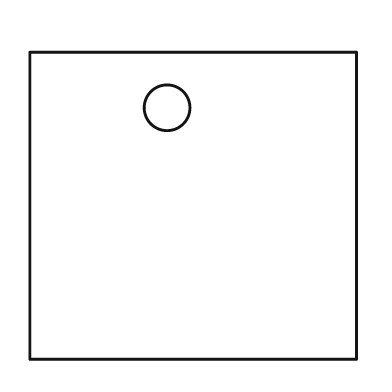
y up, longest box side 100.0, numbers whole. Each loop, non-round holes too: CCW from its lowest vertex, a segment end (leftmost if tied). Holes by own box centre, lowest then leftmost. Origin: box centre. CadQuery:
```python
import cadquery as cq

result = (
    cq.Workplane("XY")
    .moveTo(-50.0, -47.0)
    .lineTo(50.0, -47.0)
    .lineTo(50.0, 47.0)
    .lineTo(-50.0, 47.0)
    .close()
    .moveTo(-8.0, 30.0)
    .circle(7.0)
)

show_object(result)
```